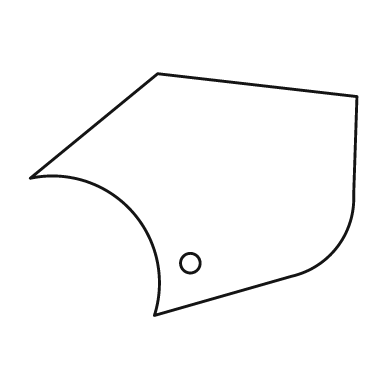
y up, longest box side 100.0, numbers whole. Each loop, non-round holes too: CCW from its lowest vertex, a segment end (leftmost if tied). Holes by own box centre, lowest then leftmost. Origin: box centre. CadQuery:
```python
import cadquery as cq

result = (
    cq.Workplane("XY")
    .moveTo(-12.0, -37.0)
    .lineTo(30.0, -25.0)
    .threePointArc((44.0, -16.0), (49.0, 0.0))
    .lineTo(50.0, 30.0)
    .lineTo(-11.0, 37.0)
    .lineTo(-50.0, 5.0)
    .threePointArc((-19.0, -5.0), (-12.0, -37.0))
    .close()
    .moveTo(-1.0, -21.0)
    .circle(3.0)
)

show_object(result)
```